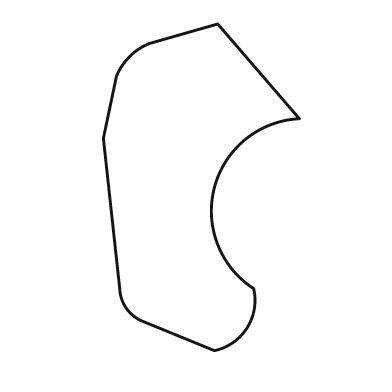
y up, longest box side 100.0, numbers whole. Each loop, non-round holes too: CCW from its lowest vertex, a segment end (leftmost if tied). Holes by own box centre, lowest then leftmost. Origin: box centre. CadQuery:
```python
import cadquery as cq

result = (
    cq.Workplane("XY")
    .moveTo(4.0, -50.0)
    .threePointArc((14.0, -43.0), (16.0, -31.0))
    .threePointArc((4.0, 0.0), (30.0, 21.0))
    .lineTo(5.0, 50.0)
    .lineTo(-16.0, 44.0)
    .threePointArc((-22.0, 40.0), (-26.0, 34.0))
    .lineTo(-30.0, 15.0)
    .lineTo(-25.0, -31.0)
    .threePointArc((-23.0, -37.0), (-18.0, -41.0))
    .close()
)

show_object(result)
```